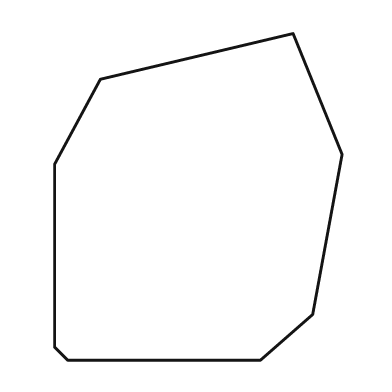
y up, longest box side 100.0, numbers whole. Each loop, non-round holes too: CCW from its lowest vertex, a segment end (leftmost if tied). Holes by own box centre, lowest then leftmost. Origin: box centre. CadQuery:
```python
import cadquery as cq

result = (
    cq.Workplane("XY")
    .moveTo(-40.0, -50.0)
    .lineTo(19.0, -50.0)
    .lineTo(35.0, -36.0)
    .lineTo(44.0, 13.0)
    .lineTo(29.0, 50.0)
    .lineTo(-30.0, 36.0)
    .lineTo(-44.0, 10.0)
    .lineTo(-44.0, -46.0)
    .close()
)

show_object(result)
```